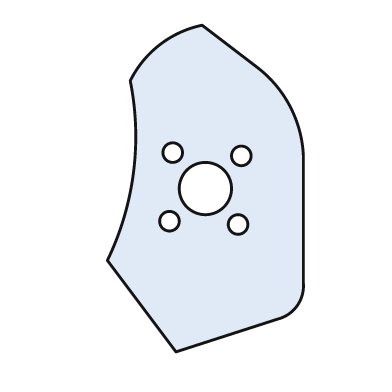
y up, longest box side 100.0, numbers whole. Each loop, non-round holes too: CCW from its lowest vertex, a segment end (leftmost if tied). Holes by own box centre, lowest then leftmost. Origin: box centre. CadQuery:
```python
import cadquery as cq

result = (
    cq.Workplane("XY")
    .moveTo(-9.0, -50.0)
    .lineTo(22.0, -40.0)
    .threePointArc((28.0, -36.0), (30.0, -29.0))
    .lineTo(30.0, 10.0)
    .threePointArc((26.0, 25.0), (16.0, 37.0))
    .lineTo(-1.0, 50.0)
    .threePointArc((-14.0, 44.0), (-23.0, 33.0))
    .threePointArc((-22.0, 5.0), (-30.0, -22.0))
    .close()
    .moveTo(10.0, -11.0)
    .circle(3.0)
    .moveTo(-11.0, -10.0)
    .circle(3.0)
    .moveTo(0.0, 0.0)
    .circle(8.0)
    .moveTo(11.0, 10.0)
    .circle(3.0)
    .moveTo(-10.0, 11.0)
    .circle(3.0)
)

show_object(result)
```